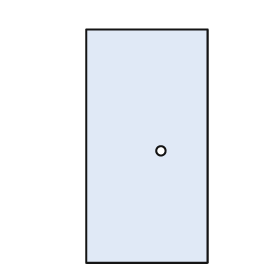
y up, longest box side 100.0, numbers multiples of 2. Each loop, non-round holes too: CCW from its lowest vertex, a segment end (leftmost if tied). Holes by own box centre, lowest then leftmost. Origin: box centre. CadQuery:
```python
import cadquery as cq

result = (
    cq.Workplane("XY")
    .moveTo(-26.0, -50.0)
    .lineTo(26.0, -50.0)
    .lineTo(26.0, 50.0)
    .lineTo(-26.0, 50.0)
    .close()
    .moveTo(6.0, -2.0)
    .circle(2.0)
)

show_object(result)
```